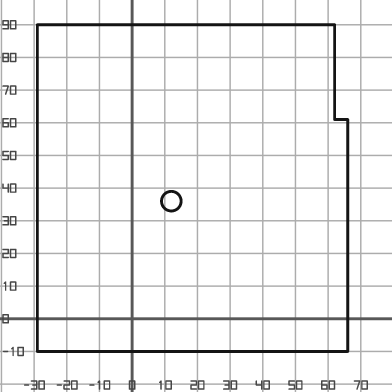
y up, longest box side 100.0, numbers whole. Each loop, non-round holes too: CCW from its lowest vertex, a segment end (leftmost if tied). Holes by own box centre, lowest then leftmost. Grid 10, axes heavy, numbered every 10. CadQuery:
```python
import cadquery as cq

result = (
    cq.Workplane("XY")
    .moveTo(-29.0, -10.0)
    .lineTo(66.0, -10.0)
    .lineTo(66.0, 61.0)
    .lineTo(62.0, 61.0)
    .lineTo(62.0, 90.0)
    .lineTo(-29.0, 90.0)
    .close()
    .moveTo(12.0, 36.0)
    .circle(3.0)
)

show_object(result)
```